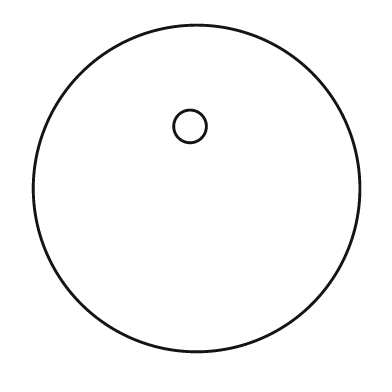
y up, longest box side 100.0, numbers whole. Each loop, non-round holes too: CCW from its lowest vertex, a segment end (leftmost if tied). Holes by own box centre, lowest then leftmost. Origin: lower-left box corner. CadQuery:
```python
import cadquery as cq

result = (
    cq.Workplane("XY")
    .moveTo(50.0, 50.0)
    .circle(50.0)
    .moveTo(48.0, 69.0)
    .circle(5.0)
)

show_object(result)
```